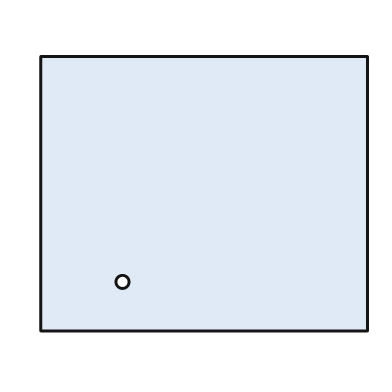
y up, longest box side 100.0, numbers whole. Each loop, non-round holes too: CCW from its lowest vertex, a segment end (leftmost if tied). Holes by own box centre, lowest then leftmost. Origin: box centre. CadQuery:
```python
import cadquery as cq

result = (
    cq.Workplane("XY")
    .moveTo(-50.0, -42.0)
    .lineTo(50.0, -42.0)
    .lineTo(50.0, 42.0)
    .lineTo(-50.0, 42.0)
    .close()
    .moveTo(-25.0, -27.0)
    .circle(2.0)
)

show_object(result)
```